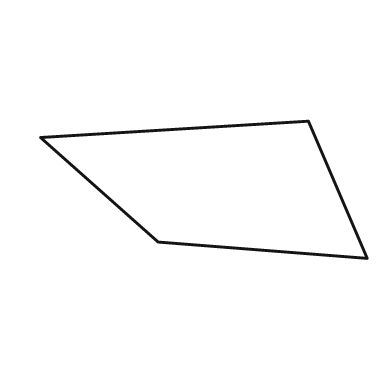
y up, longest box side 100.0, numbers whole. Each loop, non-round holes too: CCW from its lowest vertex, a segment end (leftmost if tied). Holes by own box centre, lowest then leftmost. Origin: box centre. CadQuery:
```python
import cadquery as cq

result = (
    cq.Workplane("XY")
    .moveTo(50.0, -21.0)
    .lineTo(32.0, 21.0)
    .lineTo(-50.0, 16.0)
    .lineTo(-14.0, -16.0)
    .close()
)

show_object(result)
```